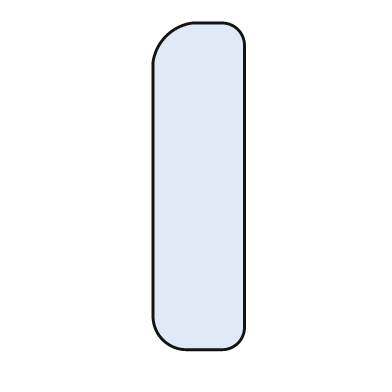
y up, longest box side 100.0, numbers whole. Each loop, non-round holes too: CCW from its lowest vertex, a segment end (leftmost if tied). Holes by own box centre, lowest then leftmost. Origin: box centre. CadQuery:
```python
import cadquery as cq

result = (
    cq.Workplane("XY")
    .moveTo(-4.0, -50.0)
    .lineTo(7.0, -50.0)
    .threePointArc((12.0, -48.0), (14.0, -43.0))
    .lineTo(14.0, 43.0)
    .threePointArc((12.0, 48.0), (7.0, 50.0))
    .lineTo(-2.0, 50.0)
    .threePointArc((-10.0, 46.0), (-14.0, 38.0))
    .lineTo(-14.0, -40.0)
    .threePointArc((-11.0, -47.0), (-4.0, -50.0))
    .close()
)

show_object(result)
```